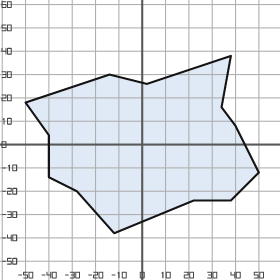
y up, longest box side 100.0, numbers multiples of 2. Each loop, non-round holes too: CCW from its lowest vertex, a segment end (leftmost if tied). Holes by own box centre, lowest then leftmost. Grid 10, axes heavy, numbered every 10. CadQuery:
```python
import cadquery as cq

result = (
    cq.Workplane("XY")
    .moveTo(-12.0, -38.0)
    .lineTo(22.0, -24.0)
    .lineTo(38.0, -24.0)
    .lineTo(50.0, -12.0)
    .lineTo(40.0, 8.0)
    .lineTo(34.0, 16.0)
    .lineTo(38.0, 38.0)
    .lineTo(2.0, 26.0)
    .lineTo(-14.0, 30.0)
    .lineTo(-50.0, 18.0)
    .lineTo(-40.0, 4.0)
    .lineTo(-40.0, -14.0)
    .lineTo(-28.0, -20.0)
    .close()
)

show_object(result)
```